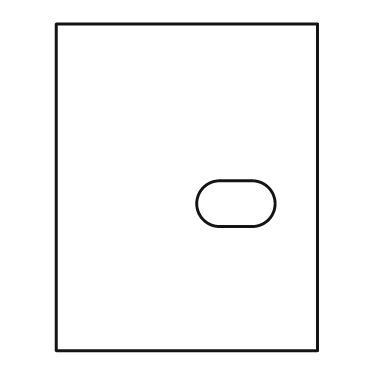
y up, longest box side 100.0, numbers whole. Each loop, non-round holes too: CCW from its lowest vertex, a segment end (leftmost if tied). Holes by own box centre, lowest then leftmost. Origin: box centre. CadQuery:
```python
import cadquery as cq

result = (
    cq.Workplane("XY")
    .moveTo(-40.0, -50.0)
    .lineTo(40.0, -50.0)
    .lineTo(40.0, 50.0)
    .lineTo(-40.0, 50.0)
    .close()
    .moveTo(10.0, -12.0)
    .lineTo(20.0, -12.0)
    .threePointArc((27.0, -5.0), (20.0, 2.0))
    .lineTo(10.0, 2.0)
    .threePointArc((3.0, -5.0), (10.0, -12.0))
    .close()
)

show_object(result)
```